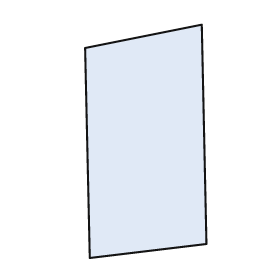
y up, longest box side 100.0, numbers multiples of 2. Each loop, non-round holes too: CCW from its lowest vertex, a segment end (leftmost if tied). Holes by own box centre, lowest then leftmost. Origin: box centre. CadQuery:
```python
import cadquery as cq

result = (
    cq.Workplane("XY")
    .moveTo(-24.0, -50.0)
    .lineTo(26.0, -44.0)
    .lineTo(24.0, 50.0)
    .lineTo(-26.0, 40.0)
    .close()
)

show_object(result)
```